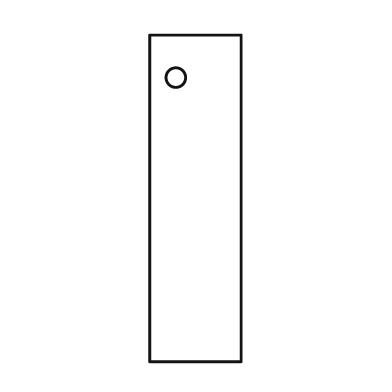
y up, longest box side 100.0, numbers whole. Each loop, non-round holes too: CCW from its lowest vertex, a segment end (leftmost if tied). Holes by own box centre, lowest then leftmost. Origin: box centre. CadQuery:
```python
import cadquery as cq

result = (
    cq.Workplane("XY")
    .moveTo(-14.0, -50.0)
    .lineTo(14.0, -50.0)
    .lineTo(14.0, 50.0)
    .lineTo(-14.0, 50.0)
    .close()
    .moveTo(-6.0, 37.0)
    .circle(3.0)
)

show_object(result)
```